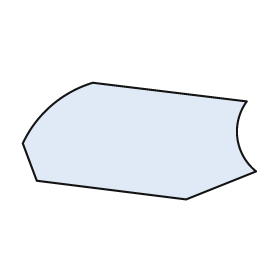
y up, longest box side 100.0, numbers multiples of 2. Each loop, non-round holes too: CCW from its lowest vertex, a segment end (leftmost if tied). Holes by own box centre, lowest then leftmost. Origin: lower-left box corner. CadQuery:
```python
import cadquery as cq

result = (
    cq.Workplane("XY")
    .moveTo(70.0, 0.0)
    .lineTo(100.0, 12.0)
    .threePointArc((92.0, 26.0), (96.0, 42.0))
    .lineTo(30.0, 50.0)
    .threePointArc((12.0, 40.0), (0.0, 24.0))
    .lineTo(6.0, 8.0)
    .close()
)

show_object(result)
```